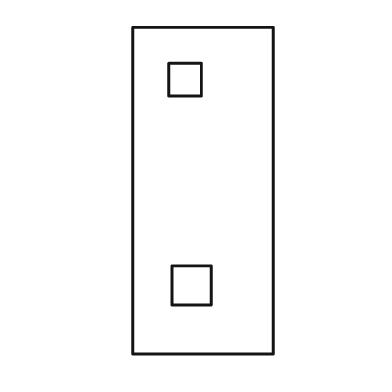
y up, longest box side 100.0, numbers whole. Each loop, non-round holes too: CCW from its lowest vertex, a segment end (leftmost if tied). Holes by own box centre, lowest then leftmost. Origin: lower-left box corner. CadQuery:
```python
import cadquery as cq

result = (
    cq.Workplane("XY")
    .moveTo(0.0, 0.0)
    .lineTo(43.0, 0.0)
    .lineTo(43.0, 100.0)
    .lineTo(0.0, 100.0)
    .close()
    .moveTo(12.0, 15.0)
    .lineTo(24.0, 15.0)
    .lineTo(24.0, 27.0)
    .lineTo(12.0, 27.0)
    .close()
    .moveTo(11.0, 79.0)
    .lineTo(21.0, 79.0)
    .lineTo(21.0, 89.0)
    .lineTo(11.0, 89.0)
    .close()
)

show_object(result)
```